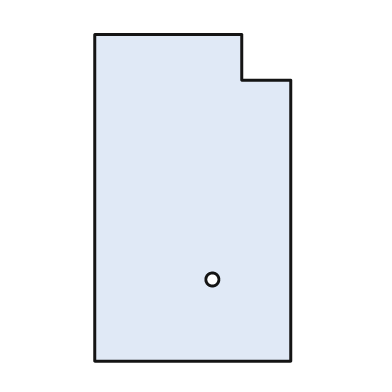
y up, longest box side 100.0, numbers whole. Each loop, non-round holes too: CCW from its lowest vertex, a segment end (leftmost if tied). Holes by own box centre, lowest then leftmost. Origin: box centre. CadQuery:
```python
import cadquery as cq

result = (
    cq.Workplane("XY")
    .moveTo(-30.0, -50.0)
    .lineTo(30.0, -50.0)
    .lineTo(30.0, 36.0)
    .lineTo(15.0, 36.0)
    .lineTo(15.0, 50.0)
    .lineTo(-30.0, 50.0)
    .close()
    .moveTo(6.0, -25.0)
    .circle(2.0)
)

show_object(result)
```